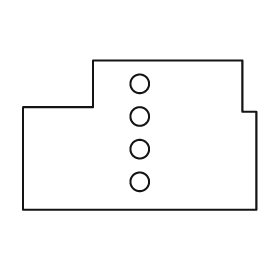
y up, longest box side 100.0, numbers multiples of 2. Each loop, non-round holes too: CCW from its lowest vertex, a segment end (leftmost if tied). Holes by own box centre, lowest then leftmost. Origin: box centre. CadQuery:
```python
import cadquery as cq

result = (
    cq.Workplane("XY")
    .moveTo(-50.0, -32.0)
    .lineTo(50.0, -32.0)
    .lineTo(50.0, 10.0)
    .lineTo(44.0, 10.0)
    .lineTo(44.0, 32.0)
    .lineTo(-20.0, 32.0)
    .lineTo(-20.0, 12.0)
    .lineTo(-50.0, 12.0)
    .close()
    .moveTo(0.0, -20.0)
    .circle(4.0)
    .moveTo(0.0, -6.0)
    .circle(4.0)
    .moveTo(0.0, 8.0)
    .circle(4.0)
    .moveTo(0.0, 22.0)
    .circle(4.0)
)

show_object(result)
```